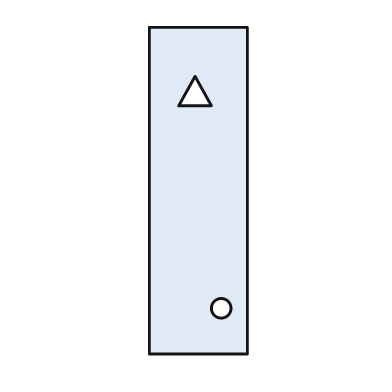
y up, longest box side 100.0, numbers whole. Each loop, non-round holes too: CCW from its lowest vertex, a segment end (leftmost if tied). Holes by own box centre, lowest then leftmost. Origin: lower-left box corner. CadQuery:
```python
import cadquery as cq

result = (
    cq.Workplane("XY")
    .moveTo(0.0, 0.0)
    .lineTo(30.0, 0.0)
    .lineTo(30.0, 100.0)
    .lineTo(0.0, 100.0)
    .close()
    .moveTo(22.0, 14.0)
    .circle(3.0)
    .moveTo(9.0, 76.0)
    .lineTo(19.0, 76.0)
    .lineTo(14.0, 85.0)
    .close()
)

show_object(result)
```